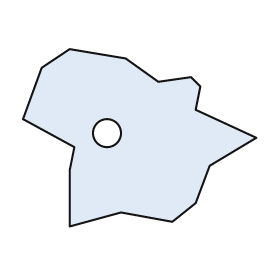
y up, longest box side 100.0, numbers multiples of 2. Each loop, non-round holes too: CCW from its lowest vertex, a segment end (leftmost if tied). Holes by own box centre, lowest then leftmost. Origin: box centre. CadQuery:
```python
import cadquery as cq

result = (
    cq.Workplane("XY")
    .moveTo(-30.0, -38.0)
    .lineTo(-8.0, -32.0)
    .lineTo(14.0, -36.0)
    .lineTo(24.0, -28.0)
    .lineTo(30.0, -12.0)
    .lineTo(50.0, 0.0)
    .lineTo(24.0, 12.0)
    .lineTo(26.0, 22.0)
    .lineTo(22.0, 26.0)
    .lineTo(8.0, 24.0)
    .lineTo(-6.0, 34.0)
    .lineTo(-30.0, 38.0)
    .lineTo(-42.0, 30.0)
    .lineTo(-50.0, 8.0)
    .lineTo(-28.0, -4.0)
    .lineTo(-30.0, -14.0)
    .close()
    .moveTo(-14.0, 2.0)
    .circle(6.0)
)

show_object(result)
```